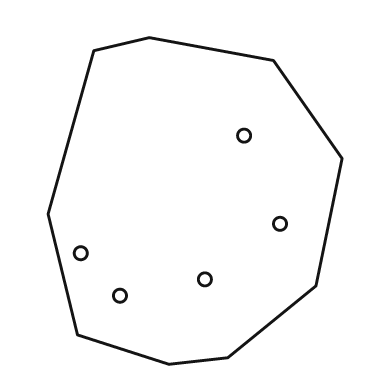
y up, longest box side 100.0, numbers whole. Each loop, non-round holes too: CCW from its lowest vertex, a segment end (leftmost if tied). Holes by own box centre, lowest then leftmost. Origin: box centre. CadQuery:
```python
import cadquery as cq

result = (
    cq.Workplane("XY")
    .moveTo(-8.0, -50.0)
    .lineTo(10.0, -48.0)
    .lineTo(37.0, -26.0)
    .lineTo(45.0, 13.0)
    .lineTo(24.0, 43.0)
    .lineTo(-14.0, 50.0)
    .lineTo(-31.0, 46.0)
    .lineTo(-45.0, -4.0)
    .lineTo(-36.0, -41.0)
    .close()
    .moveTo(-23.0, -29.0)
    .circle(2.0)
    .moveTo(3.0, -24.0)
    .circle(2.0)
    .moveTo(-35.0, -16.0)
    .circle(2.0)
    .moveTo(26.0, -7.0)
    .circle(2.0)
    .moveTo(15.0, 20.0)
    .circle(2.0)
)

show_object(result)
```